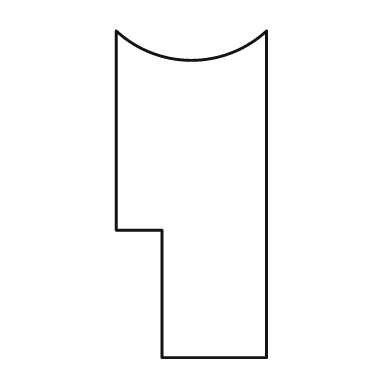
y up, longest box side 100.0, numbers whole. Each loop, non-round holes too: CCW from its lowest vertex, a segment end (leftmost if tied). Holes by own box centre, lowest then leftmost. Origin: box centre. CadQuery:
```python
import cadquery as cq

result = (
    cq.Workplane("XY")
    .moveTo(-9.0, -50.0)
    .lineTo(23.0, -50.0)
    .lineTo(23.0, 50.0)
    .threePointArc((0.0, 41.0), (-23.0, 50.0))
    .lineTo(-23.0, -11.0)
    .lineTo(-9.0, -11.0)
    .close()
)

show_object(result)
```